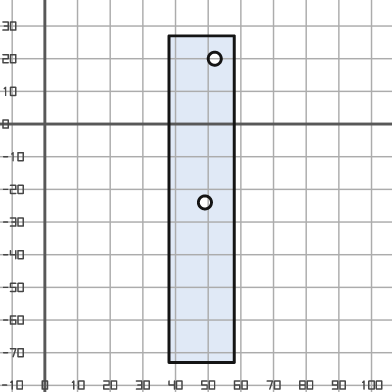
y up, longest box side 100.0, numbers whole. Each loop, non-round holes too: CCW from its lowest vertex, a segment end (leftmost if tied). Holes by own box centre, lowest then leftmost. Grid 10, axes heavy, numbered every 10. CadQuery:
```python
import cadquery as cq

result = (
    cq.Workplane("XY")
    .moveTo(38.0, -73.0)
    .lineTo(58.0, -73.0)
    .lineTo(58.0, 27.0)
    .lineTo(38.0, 27.0)
    .close()
    .moveTo(49.0, -24.0)
    .circle(2.0)
    .moveTo(52.0, 20.0)
    .circle(2.0)
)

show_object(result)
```